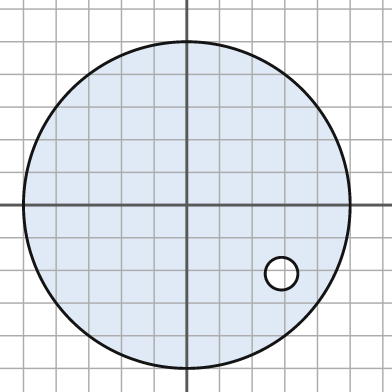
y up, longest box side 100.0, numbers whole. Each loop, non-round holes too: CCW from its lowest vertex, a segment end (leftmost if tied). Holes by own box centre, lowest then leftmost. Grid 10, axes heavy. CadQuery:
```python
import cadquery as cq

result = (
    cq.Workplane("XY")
    .moveTo(0.0, 0.0)
    .circle(50.0)
    .moveTo(29.0, -21.0)
    .circle(5.0)
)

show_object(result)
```